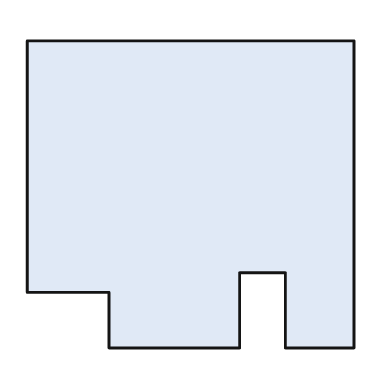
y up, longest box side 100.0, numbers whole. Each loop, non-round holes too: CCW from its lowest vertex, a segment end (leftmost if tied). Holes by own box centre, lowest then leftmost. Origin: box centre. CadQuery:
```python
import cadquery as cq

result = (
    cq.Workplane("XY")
    .moveTo(-25.0, -47.0)
    .lineTo(15.0, -47.0)
    .lineTo(15.0, -24.0)
    .lineTo(29.0, -24.0)
    .lineTo(29.0, -47.0)
    .lineTo(50.0, -47.0)
    .lineTo(50.0, 47.0)
    .lineTo(-50.0, 47.0)
    .lineTo(-50.0, -30.0)
    .lineTo(-25.0, -30.0)
    .close()
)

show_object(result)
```